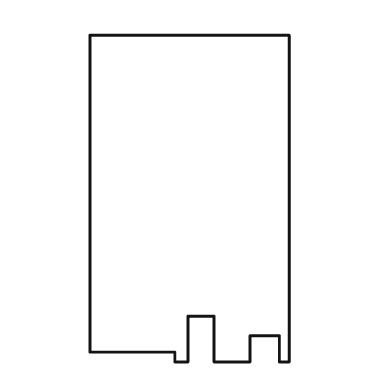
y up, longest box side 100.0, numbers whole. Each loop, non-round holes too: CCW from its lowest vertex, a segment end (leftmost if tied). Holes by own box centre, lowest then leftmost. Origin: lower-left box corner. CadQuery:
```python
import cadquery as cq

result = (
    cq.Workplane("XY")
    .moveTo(26.0, 0.0)
    .lineTo(30.0, 0.0)
    .lineTo(30.0, 14.0)
    .lineTo(38.0, 14.0)
    .lineTo(38.0, 0.0)
    .lineTo(49.0, 0.0)
    .lineTo(49.0, 8.0)
    .lineTo(58.0, 8.0)
    .lineTo(58.0, 0.0)
    .lineTo(61.0, 0.0)
    .lineTo(61.0, 100.0)
    .lineTo(0.0, 100.0)
    .lineTo(0.0, 3.0)
    .lineTo(26.0, 3.0)
    .close()
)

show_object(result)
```